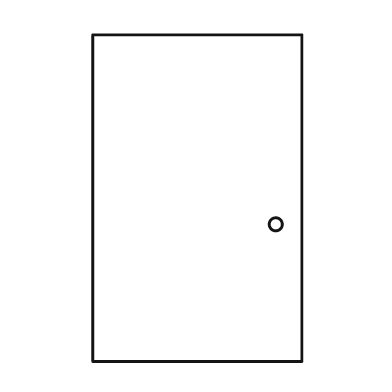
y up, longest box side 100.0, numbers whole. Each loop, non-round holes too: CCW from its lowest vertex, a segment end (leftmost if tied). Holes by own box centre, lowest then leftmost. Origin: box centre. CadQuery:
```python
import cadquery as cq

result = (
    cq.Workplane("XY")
    .moveTo(-32.0, -50.0)
    .lineTo(32.0, -50.0)
    .lineTo(32.0, 50.0)
    .lineTo(-32.0, 50.0)
    .close()
    .moveTo(24.0, -8.0)
    .circle(2.0)
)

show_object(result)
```